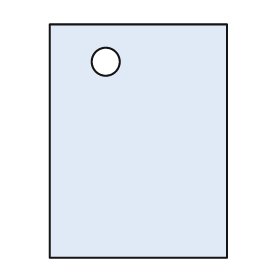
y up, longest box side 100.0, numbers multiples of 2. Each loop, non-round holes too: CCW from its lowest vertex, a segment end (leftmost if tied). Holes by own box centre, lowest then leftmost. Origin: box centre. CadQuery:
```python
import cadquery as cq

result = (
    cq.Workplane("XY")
    .moveTo(-38.0, -50.0)
    .lineTo(38.0, -50.0)
    .lineTo(38.0, 50.0)
    .lineTo(-38.0, 50.0)
    .close()
    .moveTo(-14.0, 34.0)
    .circle(6.0)
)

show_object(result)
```